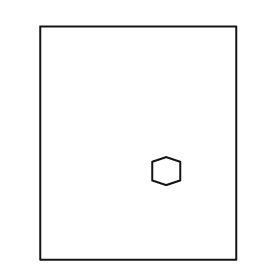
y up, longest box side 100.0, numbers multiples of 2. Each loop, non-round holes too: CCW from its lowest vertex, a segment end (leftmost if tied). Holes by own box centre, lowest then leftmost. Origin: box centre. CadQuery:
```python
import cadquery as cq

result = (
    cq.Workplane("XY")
    .moveTo(-42.0, -50.0)
    .lineTo(42.0, -50.0)
    .lineTo(42.0, 50.0)
    .lineTo(-42.0, 50.0)
    .close()
    .moveTo(12.0, -18.0)
    .lineTo(18.0, -16.0)
    .lineTo(18.0, -8.0)
    .lineTo(12.0, -6.0)
    .lineTo(6.0, -8.0)
    .lineTo(6.0, -16.0)
    .close()
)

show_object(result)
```